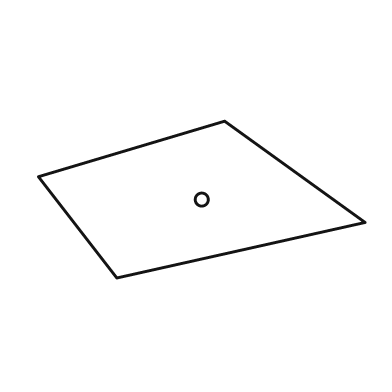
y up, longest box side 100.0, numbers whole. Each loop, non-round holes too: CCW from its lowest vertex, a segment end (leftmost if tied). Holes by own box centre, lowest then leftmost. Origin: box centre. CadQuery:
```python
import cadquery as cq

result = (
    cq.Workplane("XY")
    .moveTo(-26.0, -24.0)
    .lineTo(50.0, -7.0)
    .lineTo(7.0, 24.0)
    .lineTo(-50.0, 7.0)
    .close()
    .moveTo(0.0, 0.0)
    .circle(2.0)
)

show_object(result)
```